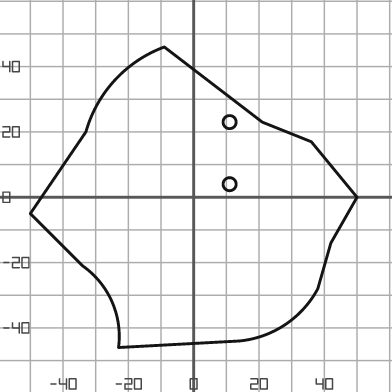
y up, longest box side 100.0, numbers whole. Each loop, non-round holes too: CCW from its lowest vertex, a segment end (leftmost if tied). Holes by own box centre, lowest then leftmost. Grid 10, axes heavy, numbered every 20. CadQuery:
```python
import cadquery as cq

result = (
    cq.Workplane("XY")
    .moveTo(-23.0, -46.0)
    .lineTo(14.0, -44.0)
    .threePointArc((28.0, -39.0), (38.0, -28.0))
    .lineTo(42.0, -14.0)
    .lineTo(50.0, 0.0)
    .lineTo(36.0, 17.0)
    .lineTo(21.0, 23.0)
    .lineTo(-9.0, 46.0)
    .threePointArc((-24.0, 36.0), (-33.0, 20.0))
    .lineTo(-50.0, -5.0)
    .lineTo(-34.0, -21.0)
    .threePointArc((-25.0, -32.0), (-23.0, -46.0))
    .close()
    .moveTo(11.0, 4.0)
    .circle(2.0)
    .moveTo(11.0, 23.0)
    .circle(2.0)
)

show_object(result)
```